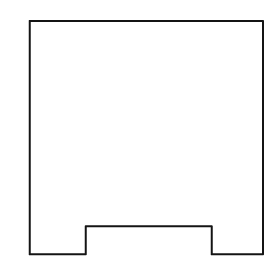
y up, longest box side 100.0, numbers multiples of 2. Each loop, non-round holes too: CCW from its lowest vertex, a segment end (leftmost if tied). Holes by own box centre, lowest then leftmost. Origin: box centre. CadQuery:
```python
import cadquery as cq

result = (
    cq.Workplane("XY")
    .moveTo(-50.0, -50.0)
    .lineTo(-26.0, -50.0)
    .lineTo(-26.0, -38.0)
    .lineTo(28.0, -38.0)
    .lineTo(28.0, -50.0)
    .lineTo(50.0, -50.0)
    .lineTo(50.0, 50.0)
    .lineTo(-50.0, 50.0)
    .close()
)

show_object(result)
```